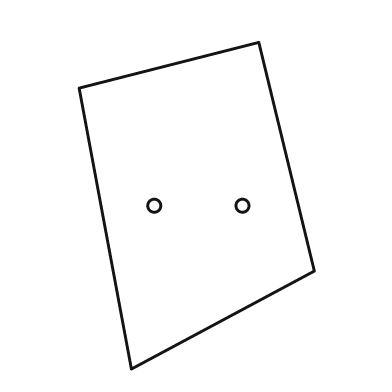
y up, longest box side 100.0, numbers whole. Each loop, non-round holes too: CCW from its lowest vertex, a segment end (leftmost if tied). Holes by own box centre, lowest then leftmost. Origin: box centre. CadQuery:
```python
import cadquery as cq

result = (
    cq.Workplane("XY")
    .moveTo(-20.0, -50.0)
    .lineTo(36.0, -20.0)
    .lineTo(19.0, 50.0)
    .lineTo(-36.0, 36.0)
    .close()
    .moveTo(-13.0, 0.0)
    .circle(2.0)
    .moveTo(14.0, 0.0)
    .circle(2.0)
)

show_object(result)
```